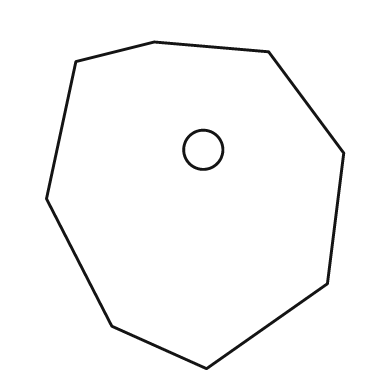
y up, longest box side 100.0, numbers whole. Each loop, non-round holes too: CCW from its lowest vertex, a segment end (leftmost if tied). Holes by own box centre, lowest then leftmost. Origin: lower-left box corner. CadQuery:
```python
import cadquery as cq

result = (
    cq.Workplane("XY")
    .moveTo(49.0, 0.0)
    .lineTo(86.0, 26.0)
    .lineTo(91.0, 66.0)
    .lineTo(68.0, 97.0)
    .lineTo(33.0, 100.0)
    .lineTo(9.0, 94.0)
    .lineTo(0.0, 52.0)
    .lineTo(20.0, 13.0)
    .close()
    .moveTo(48.0, 67.0)
    .circle(6.0)
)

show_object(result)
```